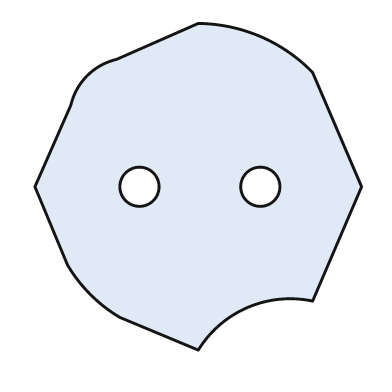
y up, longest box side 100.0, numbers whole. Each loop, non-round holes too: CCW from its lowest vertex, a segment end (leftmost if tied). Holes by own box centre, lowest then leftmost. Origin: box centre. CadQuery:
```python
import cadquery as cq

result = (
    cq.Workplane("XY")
    .moveTo(0.0, -50.0)
    .threePointArc((15.0, -37.0), (35.0, -35.0))
    .lineTo(50.0, 0.0)
    .lineTo(35.0, 35.0)
    .threePointArc((19.0, 46.0), (0.0, 50.0))
    .lineTo(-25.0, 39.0)
    .threePointArc((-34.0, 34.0), (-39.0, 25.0))
    .lineTo(-50.0, 0.0)
    .lineTo(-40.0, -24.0)
    .threePointArc((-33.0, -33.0), (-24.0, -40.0))
    .close()
    .moveTo(-18.0, 0.0)
    .circle(6.0)
    .moveTo(19.0, 0.0)
    .circle(6.0)
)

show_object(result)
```